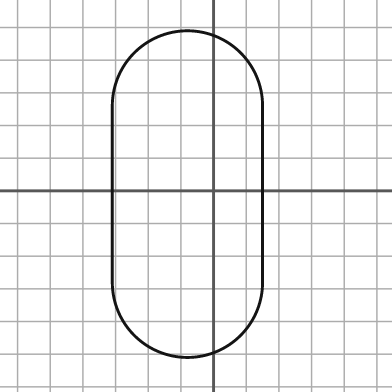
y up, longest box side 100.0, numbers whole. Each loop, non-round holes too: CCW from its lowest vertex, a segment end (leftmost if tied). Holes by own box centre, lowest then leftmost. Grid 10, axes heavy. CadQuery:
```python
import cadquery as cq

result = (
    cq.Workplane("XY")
    .moveTo(-31.0, -28.0)
    .threePointArc((-8.0, -51.0), (15.0, -28.0))
    .lineTo(15.0, 26.0)
    .threePointArc((-8.0, 49.0), (-31.0, 26.0))
    .close()
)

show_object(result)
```